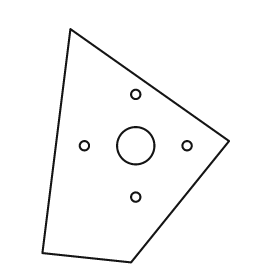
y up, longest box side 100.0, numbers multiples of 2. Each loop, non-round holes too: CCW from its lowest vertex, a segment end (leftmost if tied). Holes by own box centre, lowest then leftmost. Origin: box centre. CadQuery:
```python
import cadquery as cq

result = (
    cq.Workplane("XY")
    .moveTo(-2.0, -50.0)
    .lineTo(40.0, 2.0)
    .lineTo(-28.0, 50.0)
    .lineTo(-40.0, -46.0)
    .close()
    .moveTo(0.0, -22.0)
    .circle(2.0)
    .moveTo(-22.0, 0.0)
    .circle(2.0)
    .moveTo(0.0, 0.0)
    .circle(8.0)
    .moveTo(22.0, 0.0)
    .circle(2.0)
    .moveTo(0.0, 22.0)
    .circle(2.0)
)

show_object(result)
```